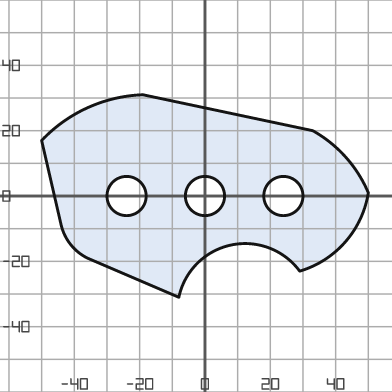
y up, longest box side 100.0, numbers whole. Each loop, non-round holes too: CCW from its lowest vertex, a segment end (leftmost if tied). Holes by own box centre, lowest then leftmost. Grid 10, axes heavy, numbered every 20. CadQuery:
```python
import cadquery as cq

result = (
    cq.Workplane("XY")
    .moveTo(-8.0, -31.0)
    .threePointArc((8.0, -15.0), (29.0, -23.0))
    .threePointArc((43.0, -14.0), (50.0, 1.0))
    .threePointArc((43.0, 12.0), (33.0, 20.0))
    .lineTo(-19.0, 31.0)
    .threePointArc((-36.0, 27.0), (-50.0, 17.0))
    .lineTo(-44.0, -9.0)
    .threePointArc((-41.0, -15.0), (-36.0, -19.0))
    .close()
    .moveTo(-24.0, 0.0)
    .circle(6.0)
    .moveTo(0.0, 0.0)
    .circle(6.0)
    .moveTo(24.0, 0.0)
    .circle(6.0)
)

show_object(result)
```